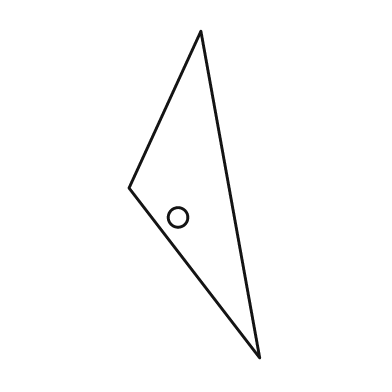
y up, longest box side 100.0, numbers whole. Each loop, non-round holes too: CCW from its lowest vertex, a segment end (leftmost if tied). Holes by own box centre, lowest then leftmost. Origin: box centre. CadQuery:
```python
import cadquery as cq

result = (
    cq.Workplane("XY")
    .moveTo(20.0, -50.0)
    .lineTo(2.0, 50.0)
    .lineTo(-20.0, 2.0)
    .close()
    .moveTo(-5.0, -7.0)
    .circle(3.0)
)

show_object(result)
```